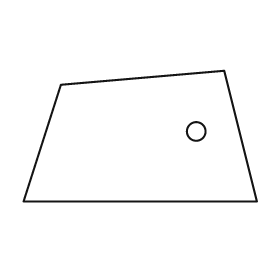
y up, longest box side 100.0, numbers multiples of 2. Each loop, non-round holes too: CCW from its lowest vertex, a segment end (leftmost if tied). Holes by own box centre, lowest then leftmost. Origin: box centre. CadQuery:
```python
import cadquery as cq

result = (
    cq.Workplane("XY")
    .moveTo(-50.0, -28.0)
    .lineTo(50.0, -28.0)
    .lineTo(36.0, 28.0)
    .lineTo(-34.0, 22.0)
    .close()
    .moveTo(24.0, 2.0)
    .circle(4.0)
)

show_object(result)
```